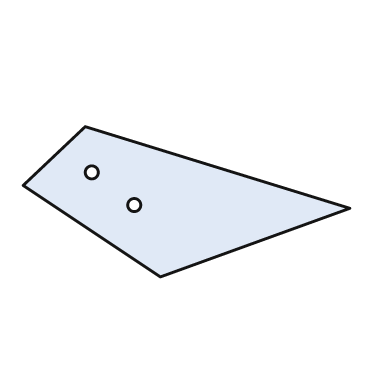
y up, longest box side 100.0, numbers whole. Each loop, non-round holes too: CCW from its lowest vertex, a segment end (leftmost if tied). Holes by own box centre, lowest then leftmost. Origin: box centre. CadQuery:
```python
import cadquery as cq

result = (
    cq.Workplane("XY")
    .moveTo(-8.0, -23.0)
    .lineTo(50.0, -2.0)
    .lineTo(-31.0, 23.0)
    .lineTo(-50.0, 5.0)
    .close()
    .moveTo(-16.0, -1.0)
    .circle(2.0)
    .moveTo(-29.0, 9.0)
    .circle(2.0)
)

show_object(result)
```